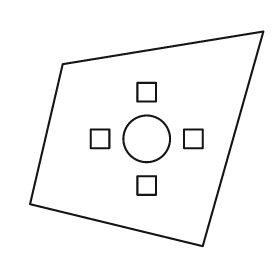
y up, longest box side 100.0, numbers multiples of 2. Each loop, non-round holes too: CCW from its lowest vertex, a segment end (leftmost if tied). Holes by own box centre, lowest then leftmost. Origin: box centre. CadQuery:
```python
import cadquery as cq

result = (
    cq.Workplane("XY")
    .moveTo(24.0, -46.0)
    .lineTo(50.0, 46.0)
    .lineTo(-36.0, 32.0)
    .lineTo(-50.0, -28.0)
    .close()
    .moveTo(-4.0, -24.0)
    .lineTo(4.0, -24.0)
    .lineTo(4.0, -16.0)
    .lineTo(-4.0, -16.0)
    .close()
    .moveTo(-24.0, -4.0)
    .lineTo(-16.0, -4.0)
    .lineTo(-16.0, 4.0)
    .lineTo(-24.0, 4.0)
    .close()
    .moveTo(0.0, 0.0)
    .circle(10.0)
    .moveTo(16.0, -4.0)
    .lineTo(24.0, -4.0)
    .lineTo(24.0, 4.0)
    .lineTo(16.0, 4.0)
    .close()
    .moveTo(-4.0, 16.0)
    .lineTo(4.0, 16.0)
    .lineTo(4.0, 24.0)
    .lineTo(-4.0, 24.0)
    .close()
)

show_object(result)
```